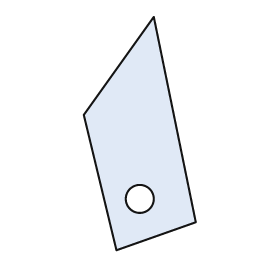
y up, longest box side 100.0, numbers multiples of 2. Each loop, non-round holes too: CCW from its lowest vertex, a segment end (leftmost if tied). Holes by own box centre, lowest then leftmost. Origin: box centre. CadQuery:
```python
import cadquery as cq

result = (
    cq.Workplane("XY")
    .moveTo(-10.0, -50.0)
    .lineTo(24.0, -38.0)
    .lineTo(6.0, 50.0)
    .lineTo(-24.0, 8.0)
    .close()
    .moveTo(0.0, -28.0)
    .circle(6.0)
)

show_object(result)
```